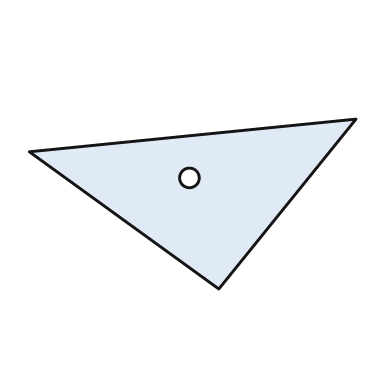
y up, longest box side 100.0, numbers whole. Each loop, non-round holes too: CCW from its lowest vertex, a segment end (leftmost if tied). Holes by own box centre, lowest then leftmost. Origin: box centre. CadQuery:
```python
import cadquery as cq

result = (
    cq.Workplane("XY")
    .moveTo(8.0, -26.0)
    .lineTo(50.0, 26.0)
    .lineTo(-50.0, 16.0)
    .close()
    .moveTo(-1.0, 8.0)
    .circle(3.0)
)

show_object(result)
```